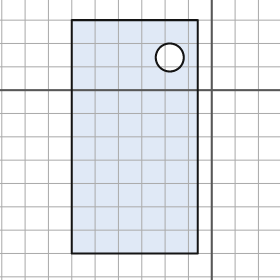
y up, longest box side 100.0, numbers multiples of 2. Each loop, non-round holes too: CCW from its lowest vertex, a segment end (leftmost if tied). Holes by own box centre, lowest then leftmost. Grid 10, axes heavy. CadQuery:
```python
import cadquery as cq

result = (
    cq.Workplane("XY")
    .moveTo(-60.0, -70.0)
    .lineTo(-6.0, -70.0)
    .lineTo(-6.0, 30.0)
    .lineTo(-60.0, 30.0)
    .close()
    .moveTo(-18.0, 14.0)
    .circle(6.0)
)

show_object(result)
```